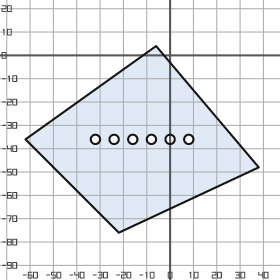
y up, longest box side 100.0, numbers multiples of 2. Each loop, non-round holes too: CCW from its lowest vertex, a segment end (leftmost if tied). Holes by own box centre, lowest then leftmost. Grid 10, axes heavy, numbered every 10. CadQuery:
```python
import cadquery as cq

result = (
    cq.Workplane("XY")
    .moveTo(-22.0, -76.0)
    .lineTo(38.0, -48.0)
    .lineTo(-6.0, 4.0)
    .lineTo(-62.0, -36.0)
    .close()
    .moveTo(-32.0, -36.0)
    .circle(2.0)
    .moveTo(-24.0, -36.0)
    .circle(2.0)
    .moveTo(-16.0, -36.0)
    .circle(2.0)
    .moveTo(-8.0, -36.0)
    .circle(2.0)
    .moveTo(0.0, -36.0)
    .circle(2.0)
    .moveTo(8.0, -36.0)
    .circle(2.0)
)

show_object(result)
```